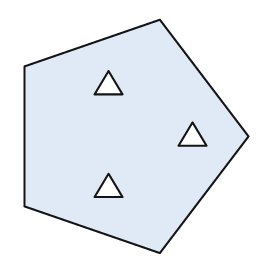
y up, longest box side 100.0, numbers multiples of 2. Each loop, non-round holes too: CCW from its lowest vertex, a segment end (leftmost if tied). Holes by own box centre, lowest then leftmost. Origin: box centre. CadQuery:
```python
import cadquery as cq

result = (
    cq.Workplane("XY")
    .moveTo(10.0, -50.0)
    .lineTo(48.0, 0.0)
    .lineTo(10.0, 50.0)
    .lineTo(-48.0, 30.0)
    .lineTo(-48.0, -30.0)
    .close()
    .moveTo(-18.0, -26.0)
    .lineTo(-6.0, -26.0)
    .lineTo(-12.0, -16.0)
    .close()
    .moveTo(18.0, -4.0)
    .lineTo(30.0, -4.0)
    .lineTo(24.0, 6.0)
    .close()
    .moveTo(-18.0, 18.0)
    .lineTo(-6.0, 18.0)
    .lineTo(-12.0, 28.0)
    .close()
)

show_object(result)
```